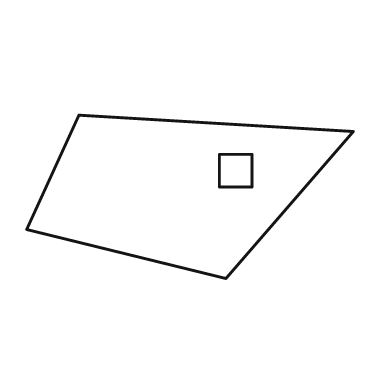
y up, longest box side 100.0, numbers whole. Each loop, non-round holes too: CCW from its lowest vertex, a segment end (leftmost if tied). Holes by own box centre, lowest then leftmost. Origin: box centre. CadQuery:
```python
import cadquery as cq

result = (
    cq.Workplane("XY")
    .moveTo(11.0, -25.0)
    .lineTo(50.0, 20.0)
    .lineTo(-34.0, 25.0)
    .lineTo(-50.0, -10.0)
    .close()
    .moveTo(9.0, 3.0)
    .lineTo(19.0, 3.0)
    .lineTo(19.0, 13.0)
    .lineTo(9.0, 13.0)
    .close()
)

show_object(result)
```